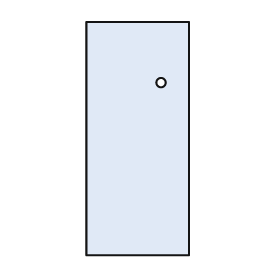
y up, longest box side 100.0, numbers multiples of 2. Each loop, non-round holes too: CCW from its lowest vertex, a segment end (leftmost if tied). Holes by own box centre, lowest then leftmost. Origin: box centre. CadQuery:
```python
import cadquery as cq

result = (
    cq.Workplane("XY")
    .moveTo(-22.0, -50.0)
    .lineTo(22.0, -50.0)
    .lineTo(22.0, 50.0)
    .lineTo(-22.0, 50.0)
    .close()
    .moveTo(10.0, 24.0)
    .circle(2.0)
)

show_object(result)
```